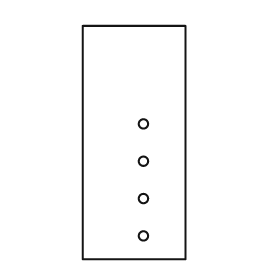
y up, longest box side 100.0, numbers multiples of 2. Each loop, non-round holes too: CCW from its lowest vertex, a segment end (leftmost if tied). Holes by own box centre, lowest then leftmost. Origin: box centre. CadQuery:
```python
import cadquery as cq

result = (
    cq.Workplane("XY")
    .moveTo(-22.0, -50.0)
    .lineTo(22.0, -50.0)
    .lineTo(22.0, 50.0)
    .lineTo(-22.0, 50.0)
    .close()
    .moveTo(4.0, -40.0)
    .circle(2.0)
    .moveTo(4.0, -24.0)
    .circle(2.0)
    .moveTo(4.0, -8.0)
    .circle(2.0)
    .moveTo(4.0, 8.0)
    .circle(2.0)
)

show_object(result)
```